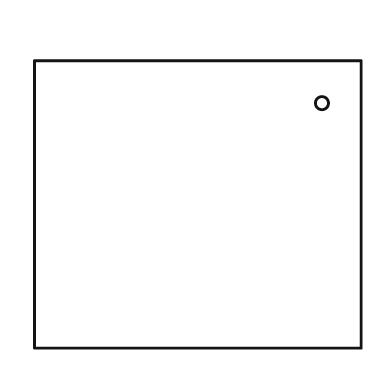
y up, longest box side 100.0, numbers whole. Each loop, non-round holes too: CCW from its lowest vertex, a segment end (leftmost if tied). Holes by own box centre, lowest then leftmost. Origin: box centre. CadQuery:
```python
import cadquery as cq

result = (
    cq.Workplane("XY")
    .moveTo(-50.0, -44.0)
    .lineTo(50.0, -44.0)
    .lineTo(50.0, 44.0)
    .lineTo(-50.0, 44.0)
    .close()
    .moveTo(38.0, 31.0)
    .circle(2.0)
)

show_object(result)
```